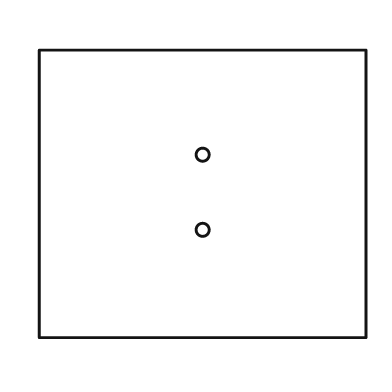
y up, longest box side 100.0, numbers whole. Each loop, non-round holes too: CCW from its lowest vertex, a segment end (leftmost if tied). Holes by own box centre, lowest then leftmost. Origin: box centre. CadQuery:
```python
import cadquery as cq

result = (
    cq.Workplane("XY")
    .moveTo(-50.0, -44.0)
    .lineTo(50.0, -44.0)
    .lineTo(50.0, 44.0)
    .lineTo(-50.0, 44.0)
    .close()
    .moveTo(0.0, -11.0)
    .circle(2.0)
    .moveTo(0.0, 12.0)
    .circle(2.0)
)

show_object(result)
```